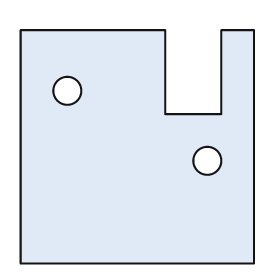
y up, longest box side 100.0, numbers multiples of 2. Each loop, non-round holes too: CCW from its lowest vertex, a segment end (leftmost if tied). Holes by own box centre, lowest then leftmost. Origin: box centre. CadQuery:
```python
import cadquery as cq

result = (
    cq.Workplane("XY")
    .moveTo(-50.0, -50.0)
    .lineTo(50.0, -50.0)
    .lineTo(50.0, 50.0)
    .lineTo(36.0, 50.0)
    .lineTo(36.0, 14.0)
    .lineTo(12.0, 14.0)
    .lineTo(12.0, 50.0)
    .lineTo(-50.0, 50.0)
    .close()
    .moveTo(30.0, -6.0)
    .circle(6.0)
    .moveTo(-30.0, 24.0)
    .circle(6.0)
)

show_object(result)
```